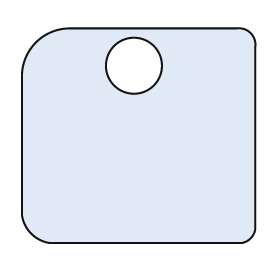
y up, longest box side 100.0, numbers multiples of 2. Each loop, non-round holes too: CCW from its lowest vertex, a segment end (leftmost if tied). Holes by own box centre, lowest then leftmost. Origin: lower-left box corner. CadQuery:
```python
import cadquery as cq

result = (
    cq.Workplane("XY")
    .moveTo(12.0, 0.0)
    .lineTo(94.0, 0.0)
    .threePointArc((98.0, 2.0), (100.0, 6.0))
    .lineTo(100.0, 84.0)
    .threePointArc((98.0, 90.0), (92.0, 92.0))
    .lineTo(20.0, 92.0)
    .threePointArc((6.0, 86.0), (0.0, 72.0))
    .lineTo(0.0, 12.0)
    .threePointArc((4.0, 4.0), (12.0, 0.0))
    .close()
    .moveTo(48.0, 76.0)
    .circle(12.0)
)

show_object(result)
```